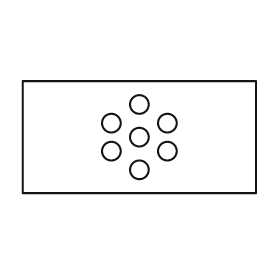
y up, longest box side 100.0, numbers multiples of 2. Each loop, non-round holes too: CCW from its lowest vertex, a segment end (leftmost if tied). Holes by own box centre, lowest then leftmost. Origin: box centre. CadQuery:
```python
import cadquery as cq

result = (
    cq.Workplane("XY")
    .moveTo(-50.0, -24.0)
    .lineTo(50.0, -24.0)
    .lineTo(50.0, 24.0)
    .lineTo(-50.0, 24.0)
    .close()
    .moveTo(0.0, -14.0)
    .circle(4.0)
    .moveTo(-12.0, -6.0)
    .circle(4.0)
    .moveTo(12.0, -6.0)
    .circle(4.0)
    .moveTo(0.0, 0.0)
    .circle(4.0)
    .moveTo(-12.0, 6.0)
    .circle(4.0)
    .moveTo(12.0, 6.0)
    .circle(4.0)
    .moveTo(0.0, 14.0)
    .circle(4.0)
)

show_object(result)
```